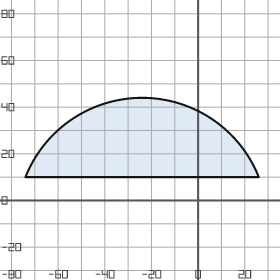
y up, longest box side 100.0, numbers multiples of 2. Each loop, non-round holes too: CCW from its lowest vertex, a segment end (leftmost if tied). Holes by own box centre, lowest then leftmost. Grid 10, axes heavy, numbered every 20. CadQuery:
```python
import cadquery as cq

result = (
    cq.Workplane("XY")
    .moveTo(-74.0, 10.0)
    .lineTo(26.0, 10.0)
    .threePointArc((-24.0, 44.0), (-74.0, 10.0))
    .close()
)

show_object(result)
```